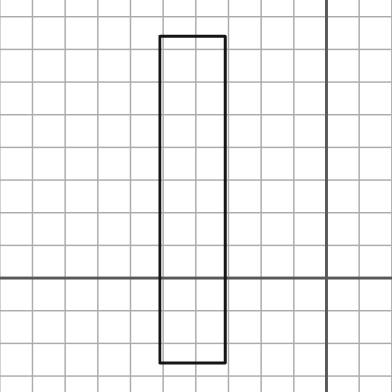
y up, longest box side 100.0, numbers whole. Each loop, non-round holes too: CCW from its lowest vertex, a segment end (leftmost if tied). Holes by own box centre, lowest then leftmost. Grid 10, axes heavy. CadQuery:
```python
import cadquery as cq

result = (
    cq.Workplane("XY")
    .moveTo(-51.0, -26.0)
    .lineTo(-31.0, -26.0)
    .lineTo(-31.0, 74.0)
    .lineTo(-51.0, 74.0)
    .close()
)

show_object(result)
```